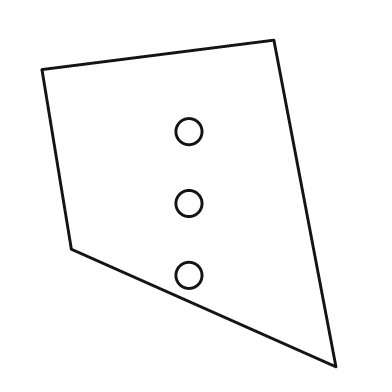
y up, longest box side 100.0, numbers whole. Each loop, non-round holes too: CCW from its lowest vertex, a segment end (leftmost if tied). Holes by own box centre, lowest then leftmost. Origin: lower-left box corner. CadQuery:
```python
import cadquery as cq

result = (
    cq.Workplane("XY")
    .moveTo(90.0, 0.0)
    .lineTo(71.0, 100.0)
    .lineTo(0.0, 91.0)
    .lineTo(9.0, 36.0)
    .close()
    .moveTo(45.0, 28.0)
    .circle(4.0)
    .moveTo(45.0, 50.0)
    .circle(4.0)
    .moveTo(45.0, 72.0)
    .circle(4.0)
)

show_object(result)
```